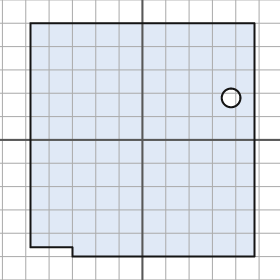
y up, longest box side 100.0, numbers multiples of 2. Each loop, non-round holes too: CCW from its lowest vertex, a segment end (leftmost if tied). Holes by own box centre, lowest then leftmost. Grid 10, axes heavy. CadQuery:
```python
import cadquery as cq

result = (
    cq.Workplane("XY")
    .moveTo(-30.0, -50.0)
    .lineTo(48.0, -50.0)
    .lineTo(48.0, 50.0)
    .lineTo(-48.0, 50.0)
    .lineTo(-48.0, -46.0)
    .lineTo(-30.0, -46.0)
    .close()
    .moveTo(38.0, 18.0)
    .circle(4.0)
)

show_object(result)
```